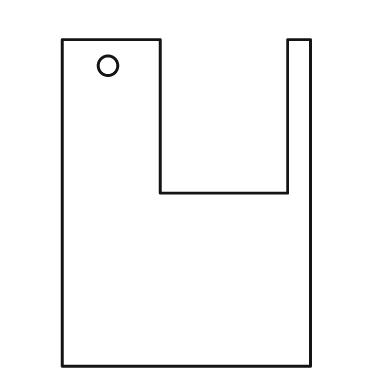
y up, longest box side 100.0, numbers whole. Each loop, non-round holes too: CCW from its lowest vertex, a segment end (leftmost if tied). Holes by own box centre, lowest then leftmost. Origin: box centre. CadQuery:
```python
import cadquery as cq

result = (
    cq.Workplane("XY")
    .moveTo(-38.0, -50.0)
    .lineTo(38.0, -50.0)
    .lineTo(38.0, 50.0)
    .lineTo(31.0, 50.0)
    .lineTo(31.0, 3.0)
    .lineTo(-8.0, 3.0)
    .lineTo(-8.0, 50.0)
    .lineTo(-38.0, 50.0)
    .close()
    .moveTo(-24.0, 42.0)
    .circle(3.0)
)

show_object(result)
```